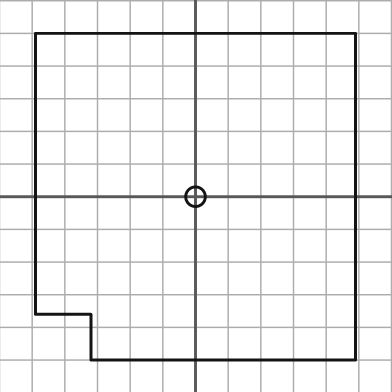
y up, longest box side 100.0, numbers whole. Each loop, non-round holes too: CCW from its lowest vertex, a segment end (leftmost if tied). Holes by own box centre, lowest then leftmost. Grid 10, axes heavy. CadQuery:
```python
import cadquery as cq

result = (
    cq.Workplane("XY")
    .moveTo(-32.0, -50.0)
    .lineTo(49.0, -50.0)
    .lineTo(49.0, 50.0)
    .lineTo(-49.0, 50.0)
    .lineTo(-49.0, -36.0)
    .lineTo(-32.0, -36.0)
    .close()
    .moveTo(0.0, 0.0)
    .circle(3.0)
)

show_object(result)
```